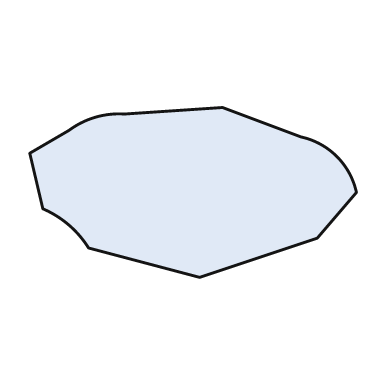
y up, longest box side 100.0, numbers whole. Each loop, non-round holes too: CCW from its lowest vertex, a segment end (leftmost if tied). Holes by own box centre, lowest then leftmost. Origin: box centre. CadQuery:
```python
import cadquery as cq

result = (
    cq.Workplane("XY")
    .moveTo(2.0, -26.0)
    .lineTo(38.0, -14.0)
    .lineTo(50.0, 0.0)
    .threePointArc((44.0, 11.0), (33.0, 17.0))
    .lineTo(9.0, 26.0)
    .lineTo(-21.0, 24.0)
    .threePointArc((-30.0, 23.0), (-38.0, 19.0))
    .lineTo(-50.0, 12.0)
    .lineTo(-46.0, -5.0)
    .threePointArc((-38.0, -10.0), (-32.0, -17.0))
    .close()
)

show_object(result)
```